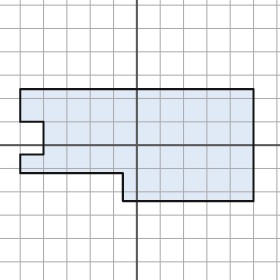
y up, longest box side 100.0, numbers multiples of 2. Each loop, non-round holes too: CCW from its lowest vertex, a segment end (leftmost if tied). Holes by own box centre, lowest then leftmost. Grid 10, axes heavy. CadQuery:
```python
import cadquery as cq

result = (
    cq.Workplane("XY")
    .moveTo(-6.0, -24.0)
    .lineTo(50.0, -24.0)
    .lineTo(50.0, 24.0)
    .lineTo(-50.0, 24.0)
    .lineTo(-50.0, 10.0)
    .lineTo(-40.0, 10.0)
    .lineTo(-40.0, -4.0)
    .lineTo(-50.0, -4.0)
    .lineTo(-50.0, -12.0)
    .lineTo(-6.0, -12.0)
    .close()
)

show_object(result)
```